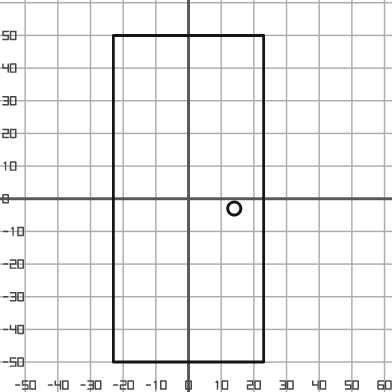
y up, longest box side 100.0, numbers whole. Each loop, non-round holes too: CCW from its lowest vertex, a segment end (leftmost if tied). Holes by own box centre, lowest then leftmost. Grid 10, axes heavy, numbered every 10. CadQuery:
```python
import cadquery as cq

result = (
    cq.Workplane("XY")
    .moveTo(-23.0, -50.0)
    .lineTo(23.0, -50.0)
    .lineTo(23.0, 50.0)
    .lineTo(-23.0, 50.0)
    .close()
    .moveTo(14.0, -3.0)
    .circle(2.0)
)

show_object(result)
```